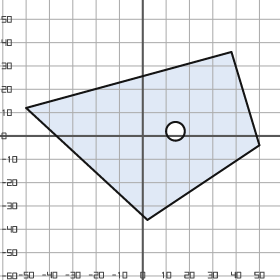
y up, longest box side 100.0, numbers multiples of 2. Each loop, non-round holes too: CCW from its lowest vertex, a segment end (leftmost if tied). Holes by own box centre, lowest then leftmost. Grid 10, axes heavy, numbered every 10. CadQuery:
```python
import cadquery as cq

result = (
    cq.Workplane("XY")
    .moveTo(2.0, -36.0)
    .lineTo(50.0, -4.0)
    .lineTo(38.0, 36.0)
    .lineTo(-50.0, 12.0)
    .close()
    .moveTo(14.0, 2.0)
    .circle(4.0)
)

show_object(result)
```